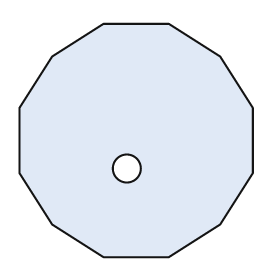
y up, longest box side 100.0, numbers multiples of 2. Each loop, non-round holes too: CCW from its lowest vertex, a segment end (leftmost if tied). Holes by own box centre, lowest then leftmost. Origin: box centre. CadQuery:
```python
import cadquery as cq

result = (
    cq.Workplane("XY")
    .moveTo(-14.0, -50.0)
    .lineTo(14.0, -50.0)
    .lineTo(36.0, -36.0)
    .lineTo(50.0, -14.0)
    .lineTo(50.0, 14.0)
    .lineTo(36.0, 36.0)
    .lineTo(14.0, 50.0)
    .lineTo(-14.0, 50.0)
    .lineTo(-36.0, 36.0)
    .lineTo(-50.0, 14.0)
    .lineTo(-50.0, -14.0)
    .lineTo(-36.0, -36.0)
    .close()
    .moveTo(-4.0, -12.0)
    .circle(6.0)
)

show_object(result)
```